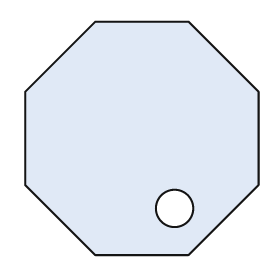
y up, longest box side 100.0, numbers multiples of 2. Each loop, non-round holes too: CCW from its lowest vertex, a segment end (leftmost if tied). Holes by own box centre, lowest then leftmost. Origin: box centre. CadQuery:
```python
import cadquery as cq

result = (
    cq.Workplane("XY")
    .moveTo(-20.0, -50.0)
    .lineTo(20.0, -50.0)
    .lineTo(50.0, -20.0)
    .lineTo(50.0, 20.0)
    .lineTo(20.0, 50.0)
    .lineTo(-20.0, 50.0)
    .lineTo(-50.0, 20.0)
    .lineTo(-50.0, -20.0)
    .close()
    .moveTo(14.0, -30.0)
    .circle(8.0)
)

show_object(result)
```